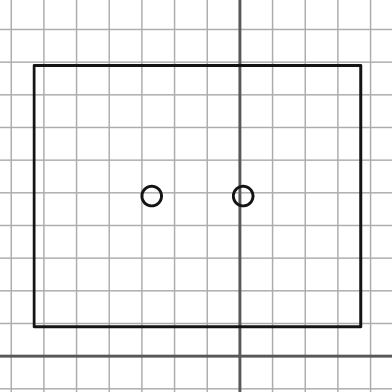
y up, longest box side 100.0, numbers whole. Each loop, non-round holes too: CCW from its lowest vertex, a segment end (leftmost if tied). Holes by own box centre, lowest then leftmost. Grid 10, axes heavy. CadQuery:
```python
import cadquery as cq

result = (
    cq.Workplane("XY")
    .moveTo(-63.0, 9.0)
    .lineTo(37.0, 9.0)
    .lineTo(37.0, 89.0)
    .lineTo(-63.0, 89.0)
    .close()
    .moveTo(-27.0, 49.0)
    .circle(3.0)
    .moveTo(1.0, 49.0)
    .circle(3.0)
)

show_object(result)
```